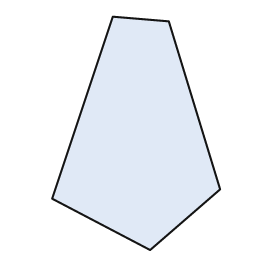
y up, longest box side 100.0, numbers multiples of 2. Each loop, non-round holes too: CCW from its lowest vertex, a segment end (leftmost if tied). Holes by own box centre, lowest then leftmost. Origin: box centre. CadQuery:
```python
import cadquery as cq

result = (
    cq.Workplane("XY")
    .moveTo(6.0, -50.0)
    .lineTo(36.0, -24.0)
    .lineTo(14.0, 48.0)
    .lineTo(-10.0, 50.0)
    .lineTo(-36.0, -28.0)
    .close()
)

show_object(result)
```